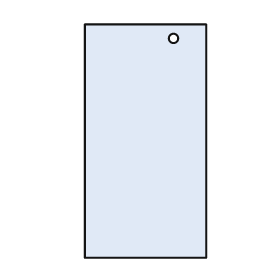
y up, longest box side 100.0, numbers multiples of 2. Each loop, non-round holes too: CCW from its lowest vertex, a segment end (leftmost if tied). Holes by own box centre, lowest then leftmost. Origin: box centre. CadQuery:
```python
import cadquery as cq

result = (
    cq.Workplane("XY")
    .moveTo(-26.0, -50.0)
    .lineTo(26.0, -50.0)
    .lineTo(26.0, 50.0)
    .lineTo(-26.0, 50.0)
    .close()
    .moveTo(12.0, 44.0)
    .circle(2.0)
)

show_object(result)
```